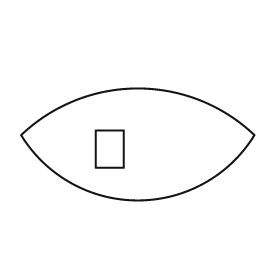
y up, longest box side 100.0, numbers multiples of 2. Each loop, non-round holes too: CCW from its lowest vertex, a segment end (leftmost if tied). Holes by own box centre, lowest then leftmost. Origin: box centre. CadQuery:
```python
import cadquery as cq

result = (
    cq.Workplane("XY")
    .moveTo(-50.0, 4.0)
    .threePointArc((0.0, -24.0), (50.0, 4.0))
    .threePointArc((0.0, 24.0), (-50.0, 4.0))
    .close()
    .moveTo(-18.0, -10.0)
    .lineTo(-6.0, -10.0)
    .lineTo(-6.0, 6.0)
    .lineTo(-18.0, 6.0)
    .close()
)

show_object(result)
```